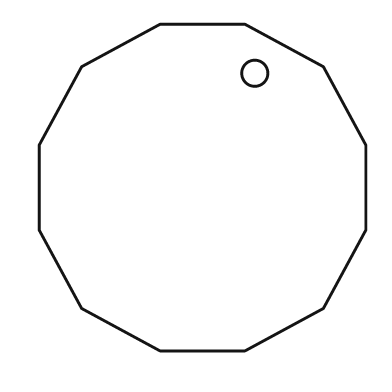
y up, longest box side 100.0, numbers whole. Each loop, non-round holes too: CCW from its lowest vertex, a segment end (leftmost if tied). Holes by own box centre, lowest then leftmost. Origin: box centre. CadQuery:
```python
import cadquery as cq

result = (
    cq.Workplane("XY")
    .moveTo(-13.0, -50.0)
    .lineTo(13.0, -50.0)
    .lineTo(37.0, -37.0)
    .lineTo(50.0, -13.0)
    .lineTo(50.0, 13.0)
    .lineTo(37.0, 37.0)
    .lineTo(13.0, 50.0)
    .lineTo(-13.0, 50.0)
    .lineTo(-37.0, 37.0)
    .lineTo(-50.0, 13.0)
    .lineTo(-50.0, -13.0)
    .lineTo(-37.0, -37.0)
    .close()
    .moveTo(16.0, 35.0)
    .circle(4.0)
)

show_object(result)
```